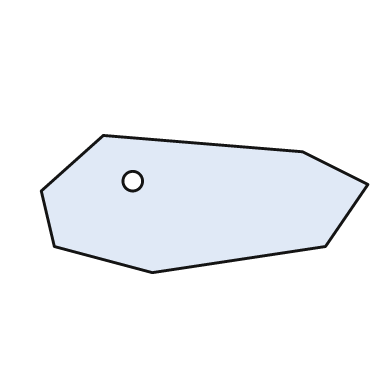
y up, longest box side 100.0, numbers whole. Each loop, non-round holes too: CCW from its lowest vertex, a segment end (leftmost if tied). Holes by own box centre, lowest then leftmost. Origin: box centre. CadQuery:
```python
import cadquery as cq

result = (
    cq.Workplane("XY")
    .moveTo(-16.0, -21.0)
    .lineTo(37.0, -13.0)
    .lineTo(50.0, 6.0)
    .lineTo(30.0, 16.0)
    .lineTo(-31.0, 21.0)
    .lineTo(-50.0, 4.0)
    .lineTo(-46.0, -13.0)
    .close()
    .moveTo(-22.0, 7.0)
    .circle(3.0)
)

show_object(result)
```